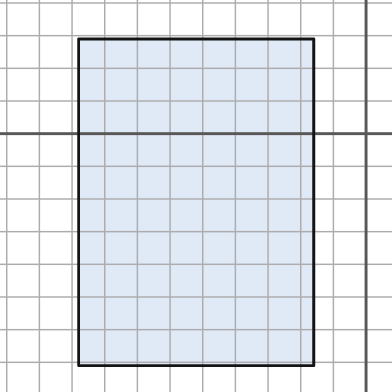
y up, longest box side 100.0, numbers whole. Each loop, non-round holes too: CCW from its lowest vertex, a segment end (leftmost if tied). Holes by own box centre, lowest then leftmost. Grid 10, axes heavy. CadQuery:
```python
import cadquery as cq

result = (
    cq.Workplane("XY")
    .moveTo(-88.0, -71.0)
    .lineTo(-16.0, -71.0)
    .lineTo(-16.0, 29.0)
    .lineTo(-88.0, 29.0)
    .close()
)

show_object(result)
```